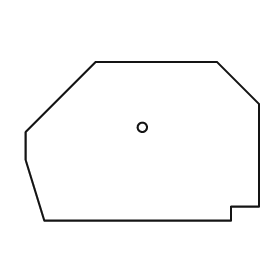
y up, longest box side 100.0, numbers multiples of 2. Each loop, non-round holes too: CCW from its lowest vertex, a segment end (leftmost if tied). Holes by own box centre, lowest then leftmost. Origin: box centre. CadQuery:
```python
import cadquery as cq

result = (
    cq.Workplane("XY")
    .moveTo(-42.0, -34.0)
    .lineTo(38.0, -34.0)
    .lineTo(38.0, -28.0)
    .lineTo(50.0, -28.0)
    .lineTo(50.0, 16.0)
    .lineTo(32.0, 34.0)
    .lineTo(-20.0, 34.0)
    .lineTo(-50.0, 4.0)
    .lineTo(-50.0, -8.0)
    .close()
    .moveTo(0.0, 6.0)
    .circle(2.0)
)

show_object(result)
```